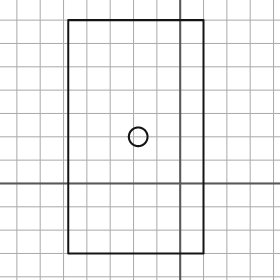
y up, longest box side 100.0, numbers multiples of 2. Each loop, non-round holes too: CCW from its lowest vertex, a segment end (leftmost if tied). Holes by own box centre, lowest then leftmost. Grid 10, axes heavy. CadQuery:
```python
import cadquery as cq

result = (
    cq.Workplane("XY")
    .moveTo(-48.0, -30.0)
    .lineTo(10.0, -30.0)
    .lineTo(10.0, 70.0)
    .lineTo(-48.0, 70.0)
    .close()
    .moveTo(-18.0, 20.0)
    .circle(4.0)
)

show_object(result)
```